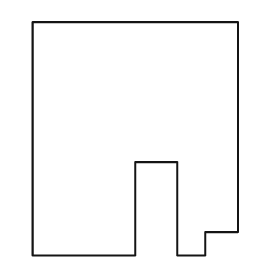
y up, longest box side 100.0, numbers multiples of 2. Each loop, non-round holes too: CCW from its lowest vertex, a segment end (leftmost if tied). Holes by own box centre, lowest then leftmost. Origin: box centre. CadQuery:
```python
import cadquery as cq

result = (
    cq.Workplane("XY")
    .moveTo(-44.0, -50.0)
    .lineTo(0.0, -50.0)
    .lineTo(0.0, -10.0)
    .lineTo(18.0, -10.0)
    .lineTo(18.0, -50.0)
    .lineTo(30.0, -50.0)
    .lineTo(30.0, -40.0)
    .lineTo(44.0, -40.0)
    .lineTo(44.0, 50.0)
    .lineTo(-44.0, 50.0)
    .close()
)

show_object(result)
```